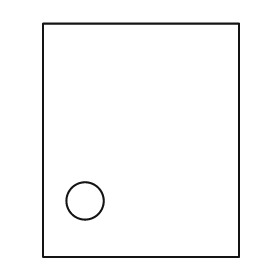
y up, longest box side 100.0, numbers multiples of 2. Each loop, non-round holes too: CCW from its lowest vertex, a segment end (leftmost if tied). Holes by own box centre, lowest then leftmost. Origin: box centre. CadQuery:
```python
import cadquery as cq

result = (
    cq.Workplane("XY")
    .moveTo(-42.0, -50.0)
    .lineTo(42.0, -50.0)
    .lineTo(42.0, 50.0)
    .lineTo(-42.0, 50.0)
    .close()
    .moveTo(-24.0, -26.0)
    .circle(8.0)
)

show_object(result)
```